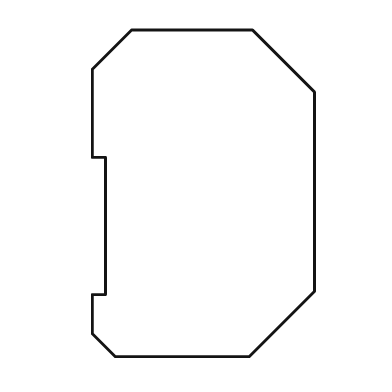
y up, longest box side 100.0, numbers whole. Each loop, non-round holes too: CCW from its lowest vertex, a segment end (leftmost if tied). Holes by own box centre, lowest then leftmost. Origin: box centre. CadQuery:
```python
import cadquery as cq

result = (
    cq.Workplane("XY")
    .moveTo(-27.0, -50.0)
    .lineTo(14.0, -50.0)
    .lineTo(34.0, -30.0)
    .lineTo(34.0, 31.0)
    .lineTo(15.0, 50.0)
    .lineTo(-22.0, 50.0)
    .lineTo(-34.0, 38.0)
    .lineTo(-34.0, 11.0)
    .lineTo(-30.0, 11.0)
    .lineTo(-30.0, -31.0)
    .lineTo(-34.0, -31.0)
    .lineTo(-34.0, -43.0)
    .close()
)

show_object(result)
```